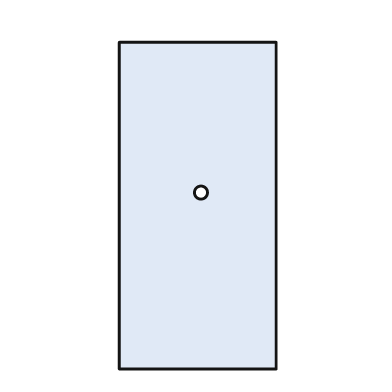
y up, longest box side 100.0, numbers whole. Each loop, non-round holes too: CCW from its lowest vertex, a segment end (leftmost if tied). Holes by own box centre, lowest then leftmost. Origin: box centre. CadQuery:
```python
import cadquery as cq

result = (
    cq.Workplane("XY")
    .moveTo(-24.0, -50.0)
    .lineTo(24.0, -50.0)
    .lineTo(24.0, 50.0)
    .lineTo(-24.0, 50.0)
    .close()
    .moveTo(1.0, 4.0)
    .circle(2.0)
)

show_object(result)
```